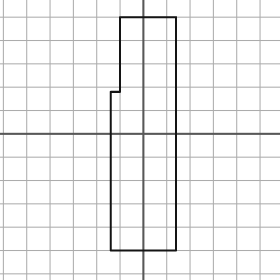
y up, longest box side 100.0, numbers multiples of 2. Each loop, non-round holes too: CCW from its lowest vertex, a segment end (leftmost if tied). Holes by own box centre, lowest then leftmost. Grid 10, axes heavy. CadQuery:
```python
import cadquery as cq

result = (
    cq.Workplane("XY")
    .moveTo(-14.0, -50.0)
    .lineTo(14.0, -50.0)
    .lineTo(14.0, 50.0)
    .lineTo(-10.0, 50.0)
    .lineTo(-10.0, 18.0)
    .lineTo(-14.0, 18.0)
    .close()
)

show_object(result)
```